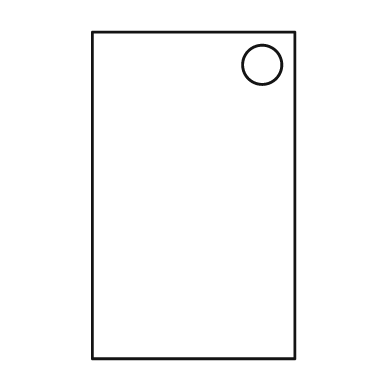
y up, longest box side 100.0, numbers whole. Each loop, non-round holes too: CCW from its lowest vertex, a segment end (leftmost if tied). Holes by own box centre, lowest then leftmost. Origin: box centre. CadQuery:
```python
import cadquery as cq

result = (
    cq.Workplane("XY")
    .moveTo(-31.0, -50.0)
    .lineTo(31.0, -50.0)
    .lineTo(31.0, 50.0)
    .lineTo(-31.0, 50.0)
    .close()
    .moveTo(21.0, 40.0)
    .circle(6.0)
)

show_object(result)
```